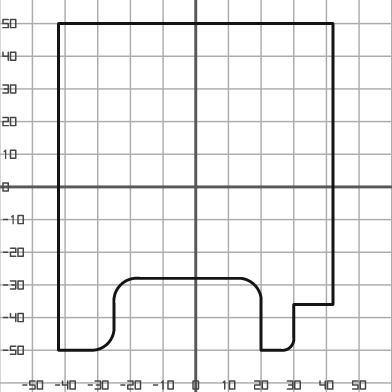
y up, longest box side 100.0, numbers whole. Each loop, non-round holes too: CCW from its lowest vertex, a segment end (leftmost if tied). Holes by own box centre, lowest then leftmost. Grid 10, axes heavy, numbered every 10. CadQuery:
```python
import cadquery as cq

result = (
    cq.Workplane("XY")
    .moveTo(-42.0, -50.0)
    .lineTo(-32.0, -50.0)
    .threePointArc((-27.0, -48.0), (-25.0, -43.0))
    .lineTo(-25.0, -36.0)
    .threePointArc((-23.0, -30.0), (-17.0, -28.0))
    .lineTo(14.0, -28.0)
    .threePointArc((18.0, -30.0), (20.0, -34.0))
    .lineTo(20.0, -50.0)
    .lineTo(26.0, -50.0)
    .threePointArc((29.0, -49.0), (30.0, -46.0))
    .lineTo(30.0, -36.0)
    .lineTo(42.0, -36.0)
    .lineTo(42.0, 50.0)
    .lineTo(-42.0, 50.0)
    .close()
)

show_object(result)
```